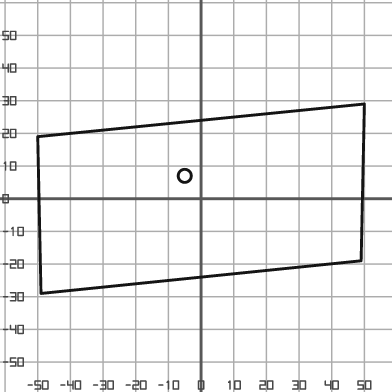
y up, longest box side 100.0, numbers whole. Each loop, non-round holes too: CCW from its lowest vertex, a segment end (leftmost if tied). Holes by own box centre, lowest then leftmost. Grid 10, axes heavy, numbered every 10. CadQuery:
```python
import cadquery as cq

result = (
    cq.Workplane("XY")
    .moveTo(-49.0, -29.0)
    .lineTo(49.0, -19.0)
    .lineTo(50.0, 29.0)
    .lineTo(-50.0, 19.0)
    .close()
    .moveTo(-5.0, 7.0)
    .circle(2.0)
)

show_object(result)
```